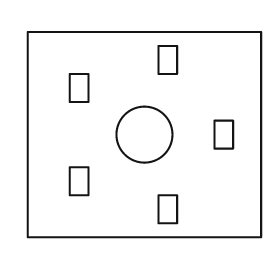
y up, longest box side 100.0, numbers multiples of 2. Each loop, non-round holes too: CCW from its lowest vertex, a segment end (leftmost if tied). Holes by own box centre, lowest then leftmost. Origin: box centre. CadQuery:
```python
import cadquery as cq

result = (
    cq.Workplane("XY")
    .moveTo(-50.0, -44.0)
    .lineTo(50.0, -44.0)
    .lineTo(50.0, 44.0)
    .lineTo(-50.0, 44.0)
    .close()
    .moveTo(6.0, -38.0)
    .lineTo(14.0, -38.0)
    .lineTo(14.0, -26.0)
    .lineTo(6.0, -26.0)
    .close()
    .moveTo(-32.0, -26.0)
    .lineTo(-24.0, -26.0)
    .lineTo(-24.0, -14.0)
    .lineTo(-32.0, -14.0)
    .close()
    .moveTo(0.0, 0.0)
    .circle(12.0)
    .moveTo(30.0, -6.0)
    .lineTo(38.0, -6.0)
    .lineTo(38.0, 6.0)
    .lineTo(30.0, 6.0)
    .close()
    .moveTo(-32.0, 14.0)
    .lineTo(-24.0, 14.0)
    .lineTo(-24.0, 26.0)
    .lineTo(-32.0, 26.0)
    .close()
    .moveTo(6.0, 26.0)
    .lineTo(14.0, 26.0)
    .lineTo(14.0, 38.0)
    .lineTo(6.0, 38.0)
    .close()
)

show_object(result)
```